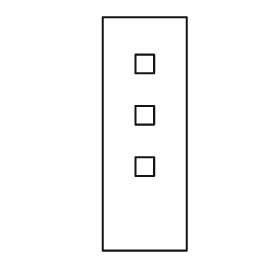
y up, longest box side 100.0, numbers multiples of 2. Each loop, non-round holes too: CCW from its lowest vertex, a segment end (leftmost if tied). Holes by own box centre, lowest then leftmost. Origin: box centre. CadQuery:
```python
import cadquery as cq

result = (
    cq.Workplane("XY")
    .moveTo(-18.0, -50.0)
    .lineTo(18.0, -50.0)
    .lineTo(18.0, 50.0)
    .lineTo(-18.0, 50.0)
    .close()
    .moveTo(-4.0, -18.0)
    .lineTo(4.0, -18.0)
    .lineTo(4.0, -10.0)
    .lineTo(-4.0, -10.0)
    .close()
    .moveTo(-4.0, 4.0)
    .lineTo(4.0, 4.0)
    .lineTo(4.0, 12.0)
    .lineTo(-4.0, 12.0)
    .close()
    .moveTo(-4.0, 26.0)
    .lineTo(4.0, 26.0)
    .lineTo(4.0, 34.0)
    .lineTo(-4.0, 34.0)
    .close()
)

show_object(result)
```